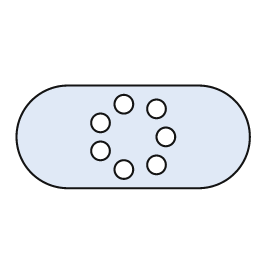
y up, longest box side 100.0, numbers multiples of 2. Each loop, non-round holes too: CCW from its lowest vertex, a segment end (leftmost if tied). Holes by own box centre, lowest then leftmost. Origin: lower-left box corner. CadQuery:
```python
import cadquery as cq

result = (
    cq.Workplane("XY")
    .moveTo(22.0, 0.0)
    .lineTo(78.0, 0.0)
    .threePointArc((100.0, 22.0), (78.0, 44.0))
    .lineTo(22.0, 44.0)
    .threePointArc((0.0, 22.0), (22.0, 0.0))
    .close()
    .moveTo(46.0, 8.0)
    .circle(4.0)
    .moveTo(60.0, 10.0)
    .circle(4.0)
    .moveTo(36.0, 16.0)
    .circle(4.0)
    .moveTo(64.0, 22.0)
    .circle(4.0)
    .moveTo(36.0, 28.0)
    .circle(4.0)
    .moveTo(60.0, 34.0)
    .circle(4.0)
    .moveTo(46.0, 36.0)
    .circle(4.0)
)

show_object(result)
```